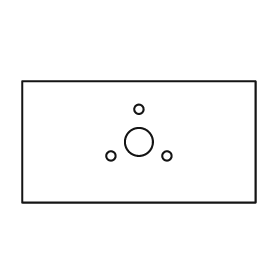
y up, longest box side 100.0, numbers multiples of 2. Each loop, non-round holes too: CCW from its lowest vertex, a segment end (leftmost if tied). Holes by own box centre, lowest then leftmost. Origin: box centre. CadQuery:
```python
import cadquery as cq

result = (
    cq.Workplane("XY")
    .moveTo(-50.0, -26.0)
    .lineTo(50.0, -26.0)
    .lineTo(50.0, 26.0)
    .lineTo(-50.0, 26.0)
    .close()
    .moveTo(-12.0, -6.0)
    .circle(2.0)
    .moveTo(12.0, -6.0)
    .circle(2.0)
    .moveTo(0.0, 0.0)
    .circle(6.0)
    .moveTo(0.0, 14.0)
    .circle(2.0)
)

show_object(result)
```